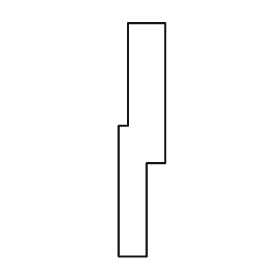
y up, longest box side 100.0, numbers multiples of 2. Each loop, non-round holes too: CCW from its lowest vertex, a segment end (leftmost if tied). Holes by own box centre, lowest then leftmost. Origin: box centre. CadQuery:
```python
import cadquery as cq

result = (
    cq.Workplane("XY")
    .moveTo(-10.0, -50.0)
    .lineTo(2.0, -50.0)
    .lineTo(2.0, -10.0)
    .lineTo(10.0, -10.0)
    .lineTo(10.0, 50.0)
    .lineTo(-6.0, 50.0)
    .lineTo(-6.0, 6.0)
    .lineTo(-10.0, 6.0)
    .close()
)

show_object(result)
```